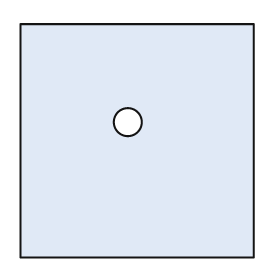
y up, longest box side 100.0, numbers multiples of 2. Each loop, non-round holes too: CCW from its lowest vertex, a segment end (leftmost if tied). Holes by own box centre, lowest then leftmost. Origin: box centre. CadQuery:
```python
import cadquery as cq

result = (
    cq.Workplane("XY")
    .moveTo(-50.0, -50.0)
    .lineTo(50.0, -50.0)
    .lineTo(50.0, 50.0)
    .lineTo(-50.0, 50.0)
    .close()
    .moveTo(-4.0, 8.0)
    .circle(6.0)
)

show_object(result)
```